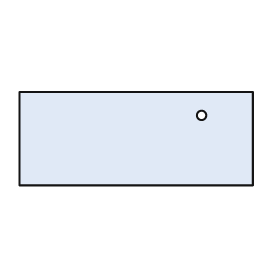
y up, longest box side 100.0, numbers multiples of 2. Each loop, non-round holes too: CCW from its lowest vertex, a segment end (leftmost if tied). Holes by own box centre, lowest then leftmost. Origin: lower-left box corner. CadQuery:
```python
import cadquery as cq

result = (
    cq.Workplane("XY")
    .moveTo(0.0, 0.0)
    .lineTo(100.0, 0.0)
    .lineTo(100.0, 40.0)
    .lineTo(0.0, 40.0)
    .close()
    .moveTo(78.0, 30.0)
    .circle(2.0)
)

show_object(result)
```